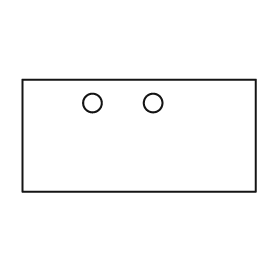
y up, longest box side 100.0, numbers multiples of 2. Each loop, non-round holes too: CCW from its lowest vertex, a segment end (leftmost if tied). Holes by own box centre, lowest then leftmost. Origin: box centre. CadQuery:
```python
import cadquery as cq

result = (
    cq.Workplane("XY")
    .moveTo(-50.0, -24.0)
    .lineTo(50.0, -24.0)
    .lineTo(50.0, 24.0)
    .lineTo(-50.0, 24.0)
    .close()
    .moveTo(-20.0, 14.0)
    .circle(4.0)
    .moveTo(6.0, 14.0)
    .circle(4.0)
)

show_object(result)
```